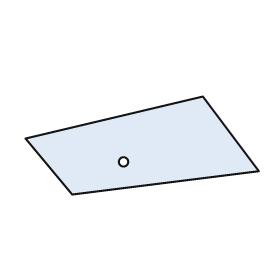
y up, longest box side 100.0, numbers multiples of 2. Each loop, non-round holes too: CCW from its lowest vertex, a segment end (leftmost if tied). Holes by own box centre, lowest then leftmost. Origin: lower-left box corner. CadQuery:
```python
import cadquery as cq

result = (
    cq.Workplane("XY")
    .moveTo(20.0, 0.0)
    .lineTo(100.0, 10.0)
    .lineTo(76.0, 42.0)
    .lineTo(0.0, 24.0)
    .close()
    .moveTo(42.0, 14.0)
    .circle(2.0)
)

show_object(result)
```